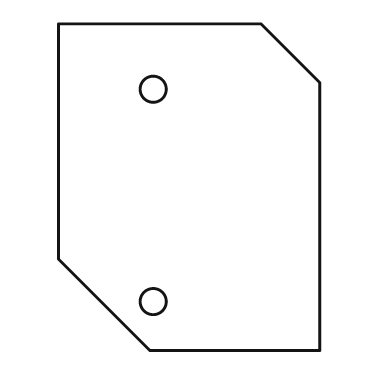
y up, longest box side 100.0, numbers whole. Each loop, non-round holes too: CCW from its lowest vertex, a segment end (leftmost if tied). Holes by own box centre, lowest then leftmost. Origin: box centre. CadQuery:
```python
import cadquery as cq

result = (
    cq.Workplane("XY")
    .moveTo(-12.0, -50.0)
    .lineTo(40.0, -50.0)
    .lineTo(40.0, 32.0)
    .lineTo(22.0, 50.0)
    .lineTo(-40.0, 50.0)
    .lineTo(-40.0, -22.0)
    .close()
    .moveTo(-11.0, -35.0)
    .circle(4.0)
    .moveTo(-11.0, 30.0)
    .circle(4.0)
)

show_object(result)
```